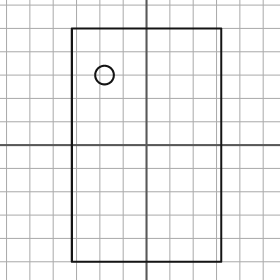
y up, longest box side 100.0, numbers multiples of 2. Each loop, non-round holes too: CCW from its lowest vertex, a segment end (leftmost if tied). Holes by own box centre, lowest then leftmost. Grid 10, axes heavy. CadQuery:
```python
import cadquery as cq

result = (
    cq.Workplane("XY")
    .moveTo(-32.0, -50.0)
    .lineTo(32.0, -50.0)
    .lineTo(32.0, 50.0)
    .lineTo(-32.0, 50.0)
    .close()
    .moveTo(-18.0, 30.0)
    .circle(4.0)
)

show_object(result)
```